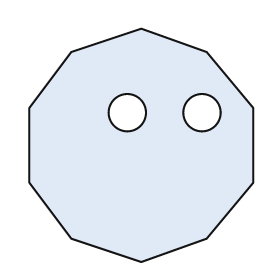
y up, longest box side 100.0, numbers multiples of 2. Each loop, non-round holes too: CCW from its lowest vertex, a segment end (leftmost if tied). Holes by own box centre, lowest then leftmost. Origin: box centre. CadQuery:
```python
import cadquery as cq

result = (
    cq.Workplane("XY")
    .moveTo(0.0, -50.0)
    .lineTo(28.0, -40.0)
    .lineTo(48.0, -16.0)
    .lineTo(48.0, 16.0)
    .lineTo(28.0, 40.0)
    .lineTo(0.0, 50.0)
    .lineTo(-30.0, 40.0)
    .lineTo(-48.0, 16.0)
    .lineTo(-48.0, -16.0)
    .lineTo(-30.0, -40.0)
    .close()
    .moveTo(-6.0, 14.0)
    .circle(8.0)
    .moveTo(26.0, 14.0)
    .circle(8.0)
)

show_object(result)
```